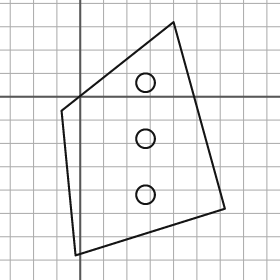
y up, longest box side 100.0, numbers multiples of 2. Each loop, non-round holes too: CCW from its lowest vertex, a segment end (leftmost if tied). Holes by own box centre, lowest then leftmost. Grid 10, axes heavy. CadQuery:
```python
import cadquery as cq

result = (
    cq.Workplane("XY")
    .moveTo(-2.0, -68.0)
    .lineTo(62.0, -48.0)
    .lineTo(40.0, 32.0)
    .lineTo(-8.0, -6.0)
    .close()
    .moveTo(28.0, -42.0)
    .circle(4.0)
    .moveTo(28.0, -18.0)
    .circle(4.0)
    .moveTo(28.0, 6.0)
    .circle(4.0)
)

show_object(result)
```